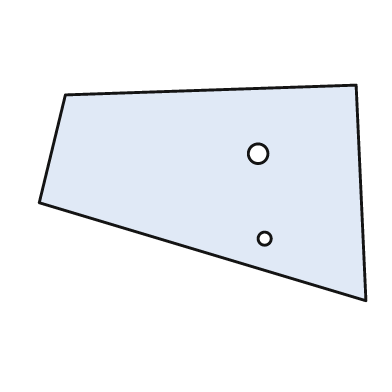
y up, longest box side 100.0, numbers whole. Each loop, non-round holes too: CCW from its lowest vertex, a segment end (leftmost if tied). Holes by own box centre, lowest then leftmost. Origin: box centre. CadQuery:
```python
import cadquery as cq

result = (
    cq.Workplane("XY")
    .moveTo(50.0, -33.0)
    .lineTo(47.0, 33.0)
    .lineTo(-42.0, 30.0)
    .lineTo(-50.0, -3.0)
    .close()
    .moveTo(19.0, -14.0)
    .circle(2.0)
    .moveTo(17.0, 12.0)
    .circle(3.0)
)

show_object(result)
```